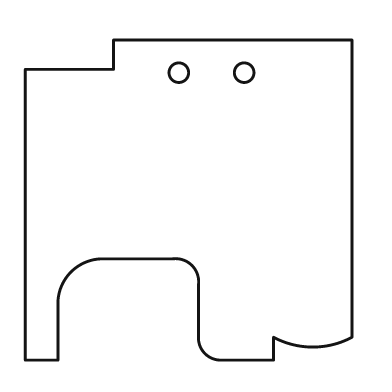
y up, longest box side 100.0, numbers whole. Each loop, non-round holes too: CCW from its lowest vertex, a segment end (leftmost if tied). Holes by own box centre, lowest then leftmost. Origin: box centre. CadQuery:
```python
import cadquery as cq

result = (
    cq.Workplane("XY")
    .moveTo(-50.0, -49.0)
    .lineTo(-40.0, -49.0)
    .lineTo(-40.0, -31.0)
    .threePointArc((-36.0, -22.0), (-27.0, -18.0))
    .lineTo(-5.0, -18.0)
    .threePointArc((1.0, -20.0), (3.0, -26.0))
    .lineTo(3.0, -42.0)
    .threePointArc((5.0, -47.0), (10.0, -49.0))
    .lineTo(26.0, -49.0)
    .lineTo(26.0, -42.0)
    .threePointArc((38.0, -45.0), (50.0, -42.0))
    .lineTo(50.0, 49.0)
    .lineTo(-23.0, 49.0)
    .lineTo(-23.0, 40.0)
    .lineTo(-50.0, 40.0)
    .close()
    .moveTo(-3.0, 39.0)
    .circle(3.0)
    .moveTo(17.0, 39.0)
    .circle(3.0)
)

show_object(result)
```